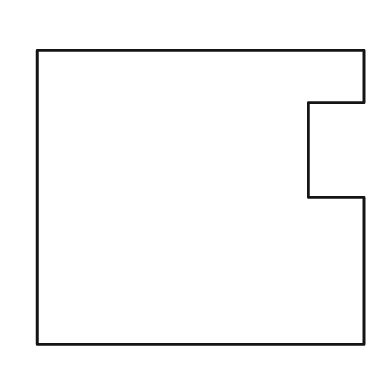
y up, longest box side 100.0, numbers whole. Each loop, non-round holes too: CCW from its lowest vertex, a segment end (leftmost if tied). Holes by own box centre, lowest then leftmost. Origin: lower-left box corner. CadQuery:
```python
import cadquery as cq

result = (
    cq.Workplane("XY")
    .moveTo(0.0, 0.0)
    .lineTo(100.0, 0.0)
    .lineTo(100.0, 45.0)
    .lineTo(83.0, 45.0)
    .lineTo(83.0, 74.0)
    .lineTo(100.0, 74.0)
    .lineTo(100.0, 90.0)
    .lineTo(0.0, 90.0)
    .close()
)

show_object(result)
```